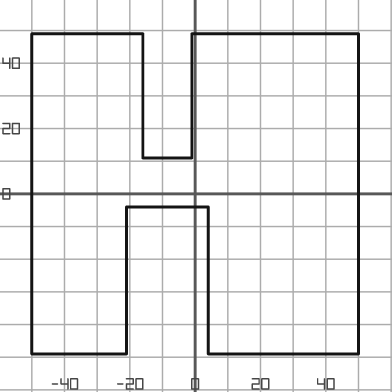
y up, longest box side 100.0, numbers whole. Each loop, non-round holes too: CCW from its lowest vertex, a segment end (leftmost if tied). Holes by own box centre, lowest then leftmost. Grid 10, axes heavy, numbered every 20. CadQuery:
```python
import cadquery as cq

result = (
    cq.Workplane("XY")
    .moveTo(-50.0, -49.0)
    .lineTo(-21.0, -49.0)
    .lineTo(-21.0, -4.0)
    .lineTo(4.0, -4.0)
    .lineTo(4.0, -49.0)
    .lineTo(50.0, -49.0)
    .lineTo(50.0, 49.0)
    .lineTo(-1.0, 49.0)
    .lineTo(-1.0, 11.0)
    .lineTo(-16.0, 11.0)
    .lineTo(-16.0, 49.0)
    .lineTo(-50.0, 49.0)
    .close()
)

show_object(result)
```